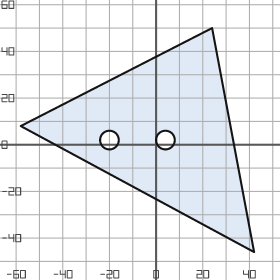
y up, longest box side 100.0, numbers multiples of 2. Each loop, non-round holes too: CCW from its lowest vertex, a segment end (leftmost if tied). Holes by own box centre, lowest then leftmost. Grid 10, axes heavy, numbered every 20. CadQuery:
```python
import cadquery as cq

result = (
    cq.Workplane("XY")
    .moveTo(42.0, -46.0)
    .lineTo(24.0, 50.0)
    .lineTo(-58.0, 8.0)
    .close()
    .moveTo(-20.0, 2.0)
    .circle(4.0)
    .moveTo(4.0, 2.0)
    .circle(4.0)
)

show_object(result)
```